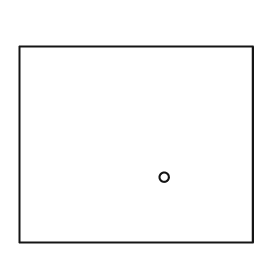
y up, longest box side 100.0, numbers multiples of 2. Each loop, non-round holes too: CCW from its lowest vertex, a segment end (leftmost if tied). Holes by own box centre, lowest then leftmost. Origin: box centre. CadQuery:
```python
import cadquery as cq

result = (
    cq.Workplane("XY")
    .moveTo(-50.0, -42.0)
    .lineTo(50.0, -42.0)
    .lineTo(50.0, 42.0)
    .lineTo(-50.0, 42.0)
    .close()
    .moveTo(12.0, -14.0)
    .circle(2.0)
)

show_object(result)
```